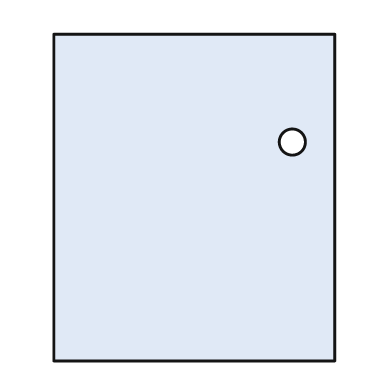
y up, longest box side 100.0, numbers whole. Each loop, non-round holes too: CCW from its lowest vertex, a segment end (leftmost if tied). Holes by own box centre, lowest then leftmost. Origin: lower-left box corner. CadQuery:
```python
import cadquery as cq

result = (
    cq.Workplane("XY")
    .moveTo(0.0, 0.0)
    .lineTo(86.0, 0.0)
    .lineTo(86.0, 100.0)
    .lineTo(0.0, 100.0)
    .close()
    .moveTo(73.0, 67.0)
    .circle(4.0)
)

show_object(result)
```